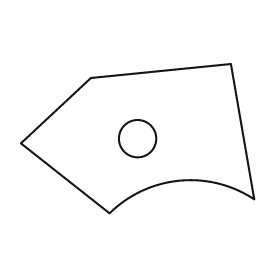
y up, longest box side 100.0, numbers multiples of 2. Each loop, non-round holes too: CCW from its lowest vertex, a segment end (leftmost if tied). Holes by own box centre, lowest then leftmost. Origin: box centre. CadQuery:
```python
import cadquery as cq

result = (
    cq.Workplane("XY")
    .moveTo(-12.0, -32.0)
    .threePointArc((18.0, -18.0), (50.0, -26.0))
    .lineTo(40.0, 32.0)
    .lineTo(-20.0, 26.0)
    .lineTo(-50.0, -2.0)
    .close()
    .moveTo(0.0, 0.0)
    .circle(8.0)
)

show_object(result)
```